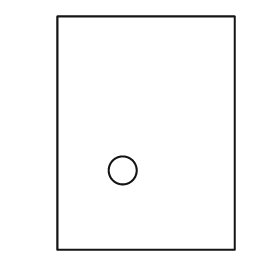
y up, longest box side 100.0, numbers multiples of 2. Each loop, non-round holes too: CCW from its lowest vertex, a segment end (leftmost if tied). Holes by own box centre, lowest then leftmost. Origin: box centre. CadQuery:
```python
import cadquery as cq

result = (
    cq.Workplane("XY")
    .moveTo(-38.0, -50.0)
    .lineTo(38.0, -50.0)
    .lineTo(38.0, 50.0)
    .lineTo(-38.0, 50.0)
    .close()
    .moveTo(-10.0, -16.0)
    .circle(6.0)
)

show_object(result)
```